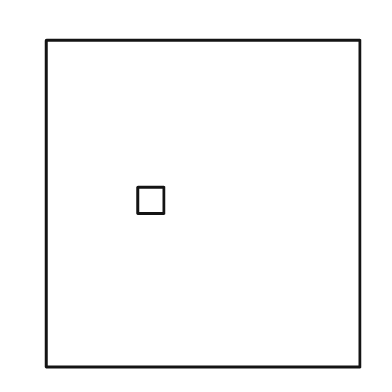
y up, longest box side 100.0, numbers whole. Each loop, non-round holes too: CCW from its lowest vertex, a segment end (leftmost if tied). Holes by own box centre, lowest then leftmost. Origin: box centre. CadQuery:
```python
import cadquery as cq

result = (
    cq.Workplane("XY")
    .moveTo(-48.0, -50.0)
    .lineTo(48.0, -50.0)
    .lineTo(48.0, 50.0)
    .lineTo(-48.0, 50.0)
    .close()
    .moveTo(-20.0, -3.0)
    .lineTo(-12.0, -3.0)
    .lineTo(-12.0, 5.0)
    .lineTo(-20.0, 5.0)
    .close()
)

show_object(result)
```